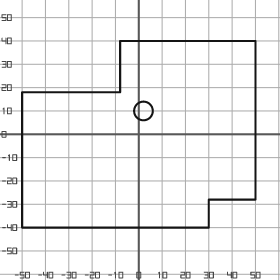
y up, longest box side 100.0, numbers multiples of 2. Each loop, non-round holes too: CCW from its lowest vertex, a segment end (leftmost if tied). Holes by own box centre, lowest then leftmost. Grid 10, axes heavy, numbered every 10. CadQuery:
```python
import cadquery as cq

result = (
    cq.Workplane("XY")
    .moveTo(-50.0, -40.0)
    .lineTo(30.0, -40.0)
    .lineTo(30.0, -28.0)
    .lineTo(50.0, -28.0)
    .lineTo(50.0, 40.0)
    .lineTo(-8.0, 40.0)
    .lineTo(-8.0, 18.0)
    .lineTo(-50.0, 18.0)
    .close()
    .moveTo(2.0, 10.0)
    .circle(4.0)
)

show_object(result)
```